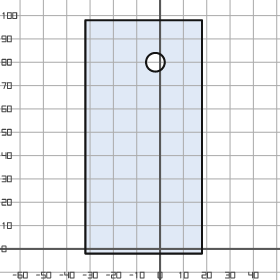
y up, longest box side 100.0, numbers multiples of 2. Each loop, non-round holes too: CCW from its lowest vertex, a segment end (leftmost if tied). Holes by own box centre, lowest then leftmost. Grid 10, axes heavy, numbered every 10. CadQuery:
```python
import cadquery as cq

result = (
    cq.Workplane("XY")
    .moveTo(-32.0, -2.0)
    .lineTo(18.0, -2.0)
    .lineTo(18.0, 98.0)
    .lineTo(-32.0, 98.0)
    .close()
    .moveTo(-2.0, 80.0)
    .circle(4.0)
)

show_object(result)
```